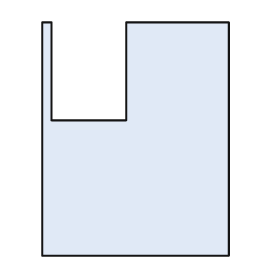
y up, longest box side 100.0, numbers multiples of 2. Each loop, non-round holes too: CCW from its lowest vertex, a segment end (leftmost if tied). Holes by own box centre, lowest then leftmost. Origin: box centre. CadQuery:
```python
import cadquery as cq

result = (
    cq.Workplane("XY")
    .moveTo(-40.0, -50.0)
    .lineTo(40.0, -50.0)
    .lineTo(40.0, 50.0)
    .lineTo(-4.0, 50.0)
    .lineTo(-4.0, 8.0)
    .lineTo(-36.0, 8.0)
    .lineTo(-36.0, 50.0)
    .lineTo(-40.0, 50.0)
    .close()
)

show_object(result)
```